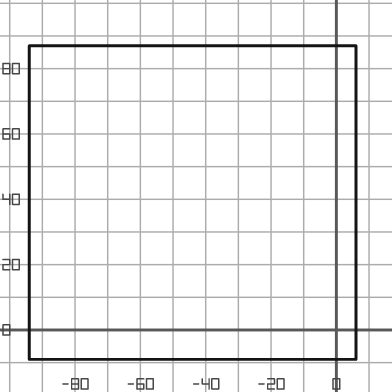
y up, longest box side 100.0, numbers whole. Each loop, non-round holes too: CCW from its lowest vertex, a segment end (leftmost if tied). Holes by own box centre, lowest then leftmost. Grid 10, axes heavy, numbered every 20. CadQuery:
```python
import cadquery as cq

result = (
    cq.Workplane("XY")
    .moveTo(-94.0, -9.0)
    .lineTo(6.0, -9.0)
    .lineTo(6.0, 87.0)
    .lineTo(-94.0, 87.0)
    .close()
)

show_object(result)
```